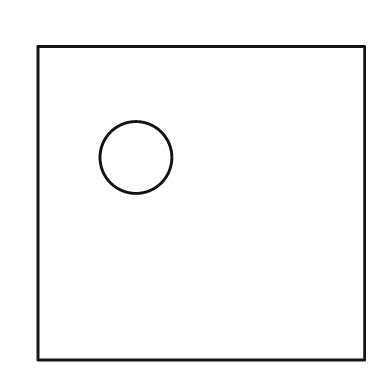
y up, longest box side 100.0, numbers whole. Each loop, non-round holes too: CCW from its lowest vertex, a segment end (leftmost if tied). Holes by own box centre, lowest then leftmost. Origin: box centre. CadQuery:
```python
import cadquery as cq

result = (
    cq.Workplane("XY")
    .moveTo(-50.0, -48.0)
    .lineTo(50.0, -48.0)
    .lineTo(50.0, 48.0)
    .lineTo(-50.0, 48.0)
    .close()
    .moveTo(-20.0, 14.0)
    .circle(11.0)
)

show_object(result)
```